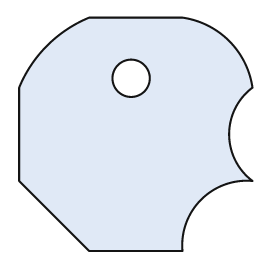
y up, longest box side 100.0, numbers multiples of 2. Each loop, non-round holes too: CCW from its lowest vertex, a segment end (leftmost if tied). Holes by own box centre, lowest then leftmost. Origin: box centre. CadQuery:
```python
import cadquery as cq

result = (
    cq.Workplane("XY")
    .moveTo(-20.0, -50.0)
    .lineTo(20.0, -50.0)
    .threePointArc((28.0, -28.0), (50.0, -20.0))
    .threePointArc((40.0, 0.0), (50.0, 20.0))
    .threePointArc((40.0, 40.0), (20.0, 50.0))
    .lineTo(-20.0, 50.0)
    .threePointArc((-38.0, 38.0), (-50.0, 20.0))
    .lineTo(-50.0, -20.0)
    .close()
    .moveTo(-2.0, 24.0)
    .circle(8.0)
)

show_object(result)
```